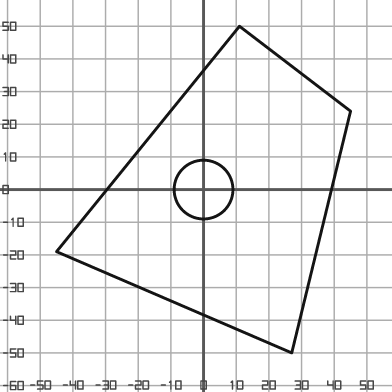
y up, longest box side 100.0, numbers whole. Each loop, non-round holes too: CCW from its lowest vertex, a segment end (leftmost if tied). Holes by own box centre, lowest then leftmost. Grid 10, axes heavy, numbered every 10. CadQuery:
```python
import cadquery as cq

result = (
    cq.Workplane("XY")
    .moveTo(27.0, -50.0)
    .lineTo(45.0, 24.0)
    .lineTo(11.0, 50.0)
    .lineTo(-45.0, -19.0)
    .close()
    .moveTo(0.0, 0.0)
    .circle(9.0)
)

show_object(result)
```